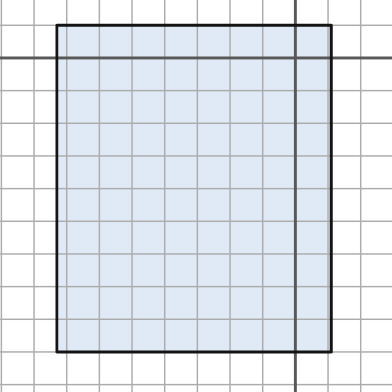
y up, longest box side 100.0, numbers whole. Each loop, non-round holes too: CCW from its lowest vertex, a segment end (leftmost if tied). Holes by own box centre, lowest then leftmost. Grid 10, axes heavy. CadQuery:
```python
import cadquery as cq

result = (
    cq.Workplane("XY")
    .moveTo(-73.0, -90.0)
    .lineTo(11.0, -90.0)
    .lineTo(11.0, 10.0)
    .lineTo(-73.0, 10.0)
    .close()
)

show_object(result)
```